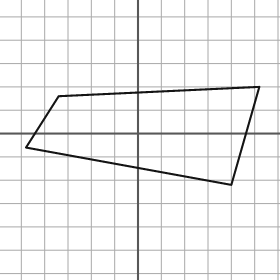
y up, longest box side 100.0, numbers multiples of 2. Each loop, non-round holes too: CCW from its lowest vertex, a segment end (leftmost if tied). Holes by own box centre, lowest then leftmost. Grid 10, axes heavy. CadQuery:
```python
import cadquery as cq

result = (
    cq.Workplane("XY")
    .moveTo(40.0, -22.0)
    .lineTo(52.0, 20.0)
    .lineTo(-34.0, 16.0)
    .lineTo(-48.0, -6.0)
    .close()
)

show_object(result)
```